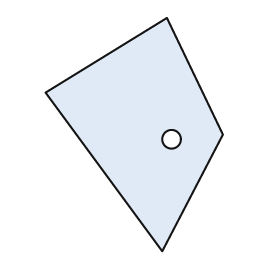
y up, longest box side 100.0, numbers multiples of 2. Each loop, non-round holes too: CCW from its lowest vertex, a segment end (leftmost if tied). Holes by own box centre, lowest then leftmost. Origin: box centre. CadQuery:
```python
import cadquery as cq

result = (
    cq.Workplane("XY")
    .moveTo(12.0, -50.0)
    .lineTo(38.0, 0.0)
    .lineTo(14.0, 50.0)
    .lineTo(-38.0, 18.0)
    .close()
    .moveTo(16.0, -2.0)
    .circle(4.0)
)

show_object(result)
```